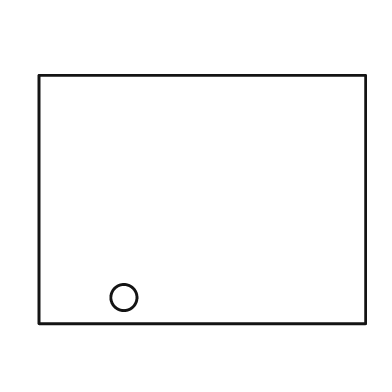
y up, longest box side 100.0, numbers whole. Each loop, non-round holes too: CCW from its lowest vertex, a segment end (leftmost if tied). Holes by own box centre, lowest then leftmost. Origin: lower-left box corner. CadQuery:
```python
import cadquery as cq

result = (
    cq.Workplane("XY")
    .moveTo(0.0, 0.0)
    .lineTo(100.0, 0.0)
    .lineTo(100.0, 76.0)
    .lineTo(0.0, 76.0)
    .close()
    .moveTo(26.0, 8.0)
    .circle(4.0)
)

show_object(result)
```